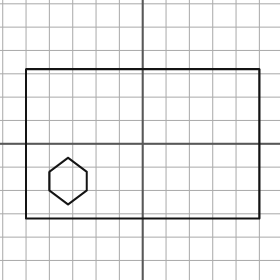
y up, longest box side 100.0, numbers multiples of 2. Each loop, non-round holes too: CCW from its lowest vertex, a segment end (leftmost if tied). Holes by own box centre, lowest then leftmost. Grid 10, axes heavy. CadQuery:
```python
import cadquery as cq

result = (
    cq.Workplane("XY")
    .moveTo(-50.0, -32.0)
    .lineTo(50.0, -32.0)
    .lineTo(50.0, 32.0)
    .lineTo(-50.0, 32.0)
    .close()
    .moveTo(-32.0, -26.0)
    .lineTo(-24.0, -20.0)
    .lineTo(-24.0, -12.0)
    .lineTo(-32.0, -6.0)
    .lineTo(-40.0, -12.0)
    .lineTo(-40.0, -20.0)
    .close()
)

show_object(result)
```